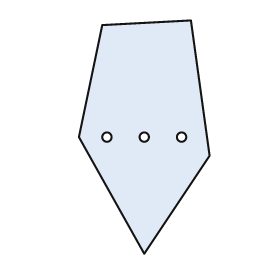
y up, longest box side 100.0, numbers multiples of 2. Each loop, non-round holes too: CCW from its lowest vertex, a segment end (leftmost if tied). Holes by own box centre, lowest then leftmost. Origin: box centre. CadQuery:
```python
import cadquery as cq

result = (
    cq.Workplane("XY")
    .moveTo(0.0, -50.0)
    .lineTo(28.0, -8.0)
    .lineTo(20.0, 50.0)
    .lineTo(-18.0, 48.0)
    .lineTo(-28.0, 0.0)
    .close()
    .moveTo(-16.0, 0.0)
    .circle(2.0)
    .moveTo(0.0, 0.0)
    .circle(2.0)
    .moveTo(16.0, 0.0)
    .circle(2.0)
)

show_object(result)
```